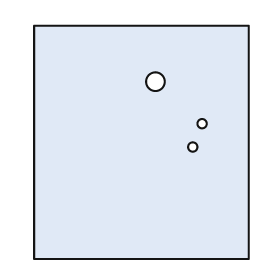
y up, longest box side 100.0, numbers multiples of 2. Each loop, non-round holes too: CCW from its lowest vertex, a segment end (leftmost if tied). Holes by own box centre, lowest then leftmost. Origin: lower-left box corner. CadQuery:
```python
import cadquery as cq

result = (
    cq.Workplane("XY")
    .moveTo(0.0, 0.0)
    .lineTo(92.0, 0.0)
    .lineTo(92.0, 100.0)
    .lineTo(0.0, 100.0)
    .close()
    .moveTo(68.0, 48.0)
    .circle(2.0)
    .moveTo(72.0, 58.0)
    .circle(2.0)
    .moveTo(52.0, 76.0)
    .circle(4.0)
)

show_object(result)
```